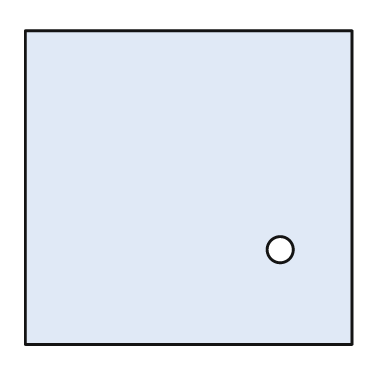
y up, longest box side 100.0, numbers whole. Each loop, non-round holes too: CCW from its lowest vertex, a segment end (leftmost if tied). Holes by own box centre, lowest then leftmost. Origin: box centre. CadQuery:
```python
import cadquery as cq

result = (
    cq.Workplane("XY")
    .moveTo(-50.0, -48.0)
    .lineTo(50.0, -48.0)
    .lineTo(50.0, 48.0)
    .lineTo(-50.0, 48.0)
    .close()
    .moveTo(28.0, -19.0)
    .circle(4.0)
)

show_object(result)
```